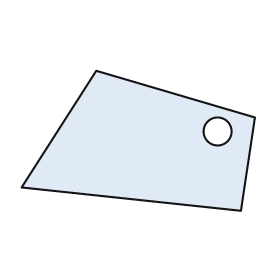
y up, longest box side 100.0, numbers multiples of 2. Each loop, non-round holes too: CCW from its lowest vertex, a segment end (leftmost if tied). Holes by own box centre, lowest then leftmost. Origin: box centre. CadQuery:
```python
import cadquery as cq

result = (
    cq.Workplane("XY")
    .moveTo(44.0, -30.0)
    .lineTo(50.0, 10.0)
    .lineTo(-18.0, 30.0)
    .lineTo(-50.0, -20.0)
    .close()
    .moveTo(34.0, 4.0)
    .circle(6.0)
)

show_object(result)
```